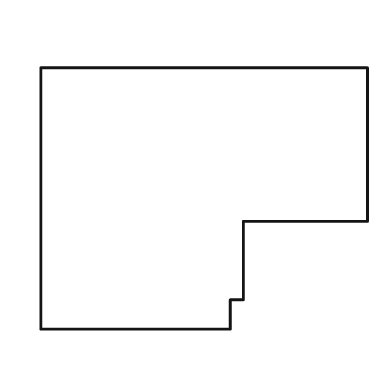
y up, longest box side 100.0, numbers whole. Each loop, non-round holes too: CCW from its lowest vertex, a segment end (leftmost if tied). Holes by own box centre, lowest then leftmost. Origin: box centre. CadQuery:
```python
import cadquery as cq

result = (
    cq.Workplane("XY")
    .moveTo(-50.0, -40.0)
    .lineTo(8.0, -40.0)
    .lineTo(8.0, -31.0)
    .lineTo(12.0, -31.0)
    .lineTo(12.0, -7.0)
    .lineTo(50.0, -7.0)
    .lineTo(50.0, 40.0)
    .lineTo(-50.0, 40.0)
    .close()
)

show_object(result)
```